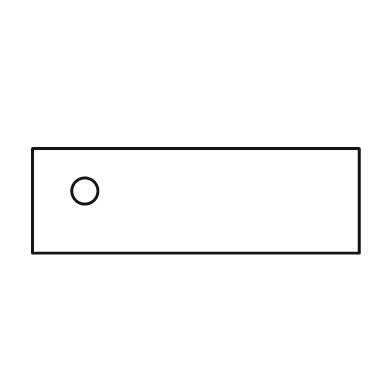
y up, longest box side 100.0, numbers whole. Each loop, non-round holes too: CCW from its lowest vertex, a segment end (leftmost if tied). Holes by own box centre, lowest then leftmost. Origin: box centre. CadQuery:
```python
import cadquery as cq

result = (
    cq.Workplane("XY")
    .moveTo(-50.0, -16.0)
    .lineTo(50.0, -16.0)
    .lineTo(50.0, 16.0)
    .lineTo(-50.0, 16.0)
    .close()
    .moveTo(-34.0, 3.0)
    .circle(4.0)
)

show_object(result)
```